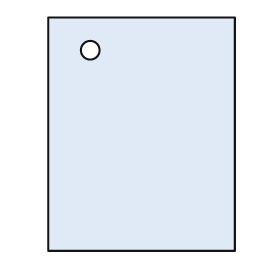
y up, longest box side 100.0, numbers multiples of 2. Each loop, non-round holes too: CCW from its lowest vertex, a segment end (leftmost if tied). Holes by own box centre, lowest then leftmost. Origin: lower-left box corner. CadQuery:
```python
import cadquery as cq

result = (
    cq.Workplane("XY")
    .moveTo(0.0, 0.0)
    .lineTo(80.0, 0.0)
    .lineTo(80.0, 100.0)
    .lineTo(0.0, 100.0)
    .close()
    .moveTo(18.0, 86.0)
    .circle(4.0)
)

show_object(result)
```